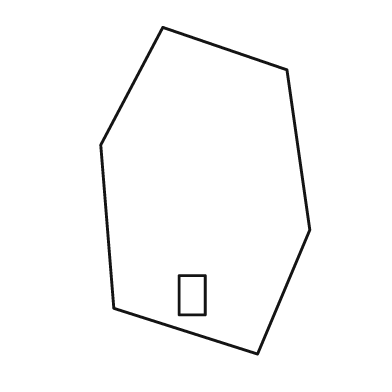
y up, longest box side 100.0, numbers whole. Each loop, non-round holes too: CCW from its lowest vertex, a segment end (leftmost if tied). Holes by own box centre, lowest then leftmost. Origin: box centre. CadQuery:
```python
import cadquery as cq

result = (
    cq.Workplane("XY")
    .moveTo(16.0, -50.0)
    .lineTo(32.0, -12.0)
    .lineTo(25.0, 37.0)
    .lineTo(-13.0, 50.0)
    .lineTo(-32.0, 14.0)
    .lineTo(-28.0, -36.0)
    .close()
    .moveTo(-8.0, -38.0)
    .lineTo(0.0, -38.0)
    .lineTo(0.0, -26.0)
    .lineTo(-8.0, -26.0)
    .close()
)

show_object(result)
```